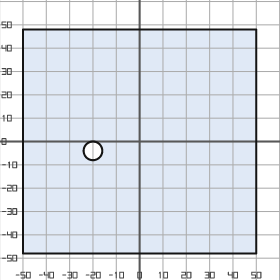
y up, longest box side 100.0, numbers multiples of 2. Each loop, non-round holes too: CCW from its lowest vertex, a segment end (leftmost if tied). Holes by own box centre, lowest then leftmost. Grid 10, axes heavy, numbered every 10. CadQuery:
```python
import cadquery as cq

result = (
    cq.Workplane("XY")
    .moveTo(-50.0, -48.0)
    .lineTo(50.0, -48.0)
    .lineTo(50.0, 48.0)
    .lineTo(-50.0, 48.0)
    .close()
    .moveTo(-20.0, -4.0)
    .circle(4.0)
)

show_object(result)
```